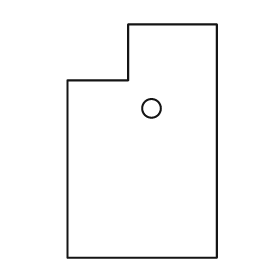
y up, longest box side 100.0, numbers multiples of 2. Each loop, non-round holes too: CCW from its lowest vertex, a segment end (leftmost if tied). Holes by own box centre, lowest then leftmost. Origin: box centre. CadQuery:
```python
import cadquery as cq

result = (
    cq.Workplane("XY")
    .moveTo(-32.0, -50.0)
    .lineTo(32.0, -50.0)
    .lineTo(32.0, 50.0)
    .lineTo(-6.0, 50.0)
    .lineTo(-6.0, 26.0)
    .lineTo(-32.0, 26.0)
    .close()
    .moveTo(4.0, 14.0)
    .circle(4.0)
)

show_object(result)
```